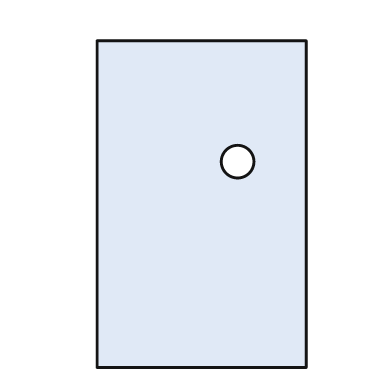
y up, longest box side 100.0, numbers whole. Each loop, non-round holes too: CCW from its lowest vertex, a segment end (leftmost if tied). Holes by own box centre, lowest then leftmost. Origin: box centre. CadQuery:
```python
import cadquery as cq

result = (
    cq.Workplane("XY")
    .moveTo(-32.0, -50.0)
    .lineTo(32.0, -50.0)
    .lineTo(32.0, 50.0)
    .lineTo(-32.0, 50.0)
    .close()
    .moveTo(11.0, 13.0)
    .circle(5.0)
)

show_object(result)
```